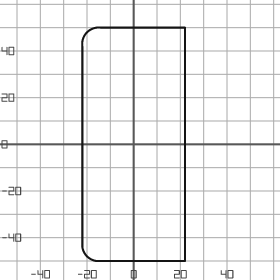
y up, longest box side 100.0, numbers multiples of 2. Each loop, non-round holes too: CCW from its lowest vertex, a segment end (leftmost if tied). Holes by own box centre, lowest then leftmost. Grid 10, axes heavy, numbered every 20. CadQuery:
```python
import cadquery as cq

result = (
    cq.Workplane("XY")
    .moveTo(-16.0, -50.0)
    .lineTo(22.0, -50.0)
    .lineTo(22.0, 50.0)
    .lineTo(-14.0, 50.0)
    .threePointArc((-20.0, 48.0), (-22.0, 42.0))
    .lineTo(-22.0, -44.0)
    .threePointArc((-20.0, -48.0), (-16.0, -50.0))
    .close()
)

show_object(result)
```